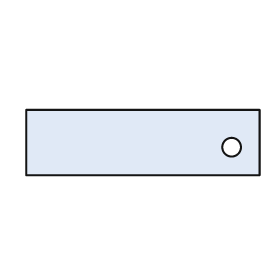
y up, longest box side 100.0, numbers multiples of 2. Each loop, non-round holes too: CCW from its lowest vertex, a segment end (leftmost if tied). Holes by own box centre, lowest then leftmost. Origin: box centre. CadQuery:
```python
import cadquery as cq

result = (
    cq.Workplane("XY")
    .moveTo(-50.0, -14.0)
    .lineTo(50.0, -14.0)
    .lineTo(50.0, 14.0)
    .lineTo(-50.0, 14.0)
    .close()
    .moveTo(38.0, -2.0)
    .circle(4.0)
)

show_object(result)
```